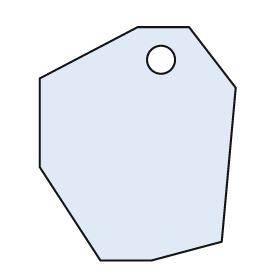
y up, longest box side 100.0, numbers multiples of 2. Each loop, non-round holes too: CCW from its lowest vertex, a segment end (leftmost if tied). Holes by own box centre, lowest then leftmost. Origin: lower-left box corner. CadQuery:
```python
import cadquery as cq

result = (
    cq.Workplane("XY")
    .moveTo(26.0, 0.0)
    .lineTo(48.0, 0.0)
    .lineTo(78.0, 8.0)
    .lineTo(84.0, 74.0)
    .lineTo(64.0, 100.0)
    .lineTo(42.0, 100.0)
    .lineTo(0.0, 78.0)
    .lineTo(0.0, 40.0)
    .close()
    .moveTo(52.0, 86.0)
    .circle(6.0)
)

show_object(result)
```